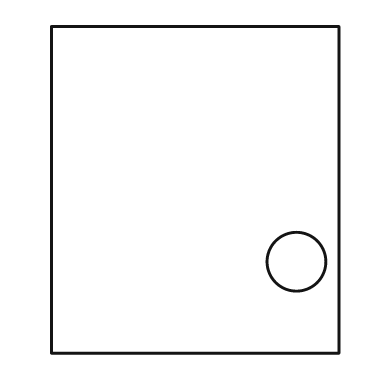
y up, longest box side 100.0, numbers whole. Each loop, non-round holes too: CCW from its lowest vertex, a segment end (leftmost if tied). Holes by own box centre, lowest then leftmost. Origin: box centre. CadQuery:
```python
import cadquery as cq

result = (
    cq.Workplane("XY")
    .moveTo(-44.0, -50.0)
    .lineTo(44.0, -50.0)
    .lineTo(44.0, 50.0)
    .lineTo(-44.0, 50.0)
    .close()
    .moveTo(31.0, -22.0)
    .circle(9.0)
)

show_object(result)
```